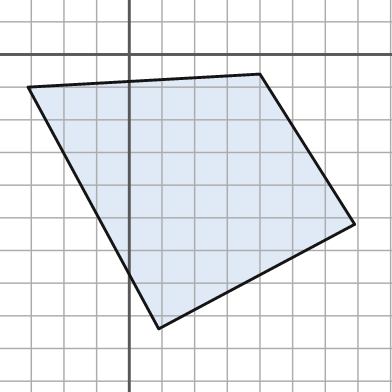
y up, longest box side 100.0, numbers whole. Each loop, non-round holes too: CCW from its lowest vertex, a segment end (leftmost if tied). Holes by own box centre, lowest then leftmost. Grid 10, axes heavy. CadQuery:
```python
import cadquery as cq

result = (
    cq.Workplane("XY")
    .moveTo(9.0, -84.0)
    .lineTo(69.0, -52.0)
    .lineTo(40.0, -6.0)
    .lineTo(-31.0, -10.0)
    .close()
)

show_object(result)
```